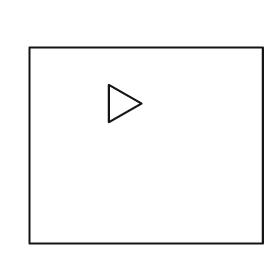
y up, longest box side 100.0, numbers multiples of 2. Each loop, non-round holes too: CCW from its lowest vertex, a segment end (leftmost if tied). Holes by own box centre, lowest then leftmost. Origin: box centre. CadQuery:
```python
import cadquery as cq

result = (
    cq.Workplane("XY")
    .moveTo(-50.0, -42.0)
    .lineTo(50.0, -42.0)
    .lineTo(50.0, 42.0)
    .lineTo(-50.0, 42.0)
    .close()
    .moveTo(-16.0, 10.0)
    .lineTo(-2.0, 18.0)
    .lineTo(-16.0, 26.0)
    .close()
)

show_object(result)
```